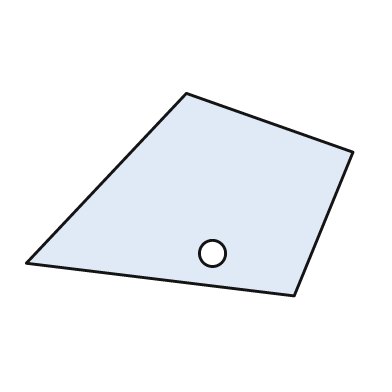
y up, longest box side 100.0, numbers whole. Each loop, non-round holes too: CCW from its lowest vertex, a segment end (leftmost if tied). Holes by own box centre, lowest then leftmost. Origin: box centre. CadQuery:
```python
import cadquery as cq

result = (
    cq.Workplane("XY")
    .moveTo(32.0, -31.0)
    .lineTo(50.0, 13.0)
    .lineTo(-1.0, 31.0)
    .lineTo(-50.0, -21.0)
    .close()
    .moveTo(7.0, -18.0)
    .circle(4.0)
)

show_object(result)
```